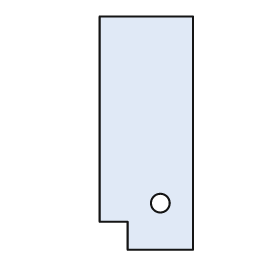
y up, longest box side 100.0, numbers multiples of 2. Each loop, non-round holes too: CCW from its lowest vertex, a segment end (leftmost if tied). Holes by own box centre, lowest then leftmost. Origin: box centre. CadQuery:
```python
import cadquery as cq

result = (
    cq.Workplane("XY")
    .moveTo(-8.0, -50.0)
    .lineTo(20.0, -50.0)
    .lineTo(20.0, 50.0)
    .lineTo(-20.0, 50.0)
    .lineTo(-20.0, -38.0)
    .lineTo(-8.0, -38.0)
    .close()
    .moveTo(6.0, -30.0)
    .circle(4.0)
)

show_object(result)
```